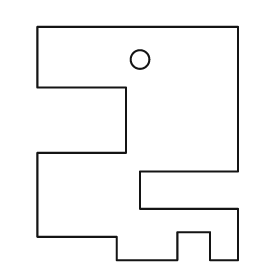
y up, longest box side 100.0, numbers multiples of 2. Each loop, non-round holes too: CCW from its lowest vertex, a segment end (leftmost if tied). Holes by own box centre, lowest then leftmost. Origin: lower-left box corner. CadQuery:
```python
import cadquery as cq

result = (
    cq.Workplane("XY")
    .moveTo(34.0, 0.0)
    .lineTo(60.0, 0.0)
    .lineTo(60.0, 12.0)
    .lineTo(74.0, 12.0)
    .lineTo(74.0, 0.0)
    .lineTo(86.0, 0.0)
    .lineTo(86.0, 22.0)
    .lineTo(44.0, 22.0)
    .lineTo(44.0, 38.0)
    .lineTo(86.0, 38.0)
    .lineTo(86.0, 100.0)
    .lineTo(0.0, 100.0)
    .lineTo(0.0, 74.0)
    .lineTo(38.0, 74.0)
    .lineTo(38.0, 46.0)
    .lineTo(0.0, 46.0)
    .lineTo(0.0, 10.0)
    .lineTo(34.0, 10.0)
    .close()
    .moveTo(44.0, 86.0)
    .circle(4.0)
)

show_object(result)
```